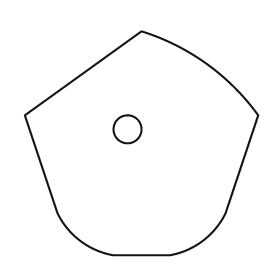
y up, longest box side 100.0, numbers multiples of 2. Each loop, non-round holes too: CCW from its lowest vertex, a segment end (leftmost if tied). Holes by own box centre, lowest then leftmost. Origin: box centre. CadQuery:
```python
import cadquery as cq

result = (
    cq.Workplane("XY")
    .moveTo(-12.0, -48.0)
    .lineTo(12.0, -48.0)
    .threePointArc((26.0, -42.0), (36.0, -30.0))
    .lineTo(50.0, 12.0)
    .threePointArc((28.0, 34.0), (0.0, 48.0))
    .lineTo(-50.0, 12.0)
    .lineTo(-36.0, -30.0)
    .threePointArc((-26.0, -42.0), (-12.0, -48.0))
    .close()
    .moveTo(-6.0, 6.0)
    .circle(6.0)
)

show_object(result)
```